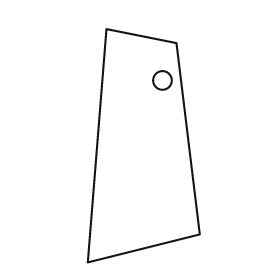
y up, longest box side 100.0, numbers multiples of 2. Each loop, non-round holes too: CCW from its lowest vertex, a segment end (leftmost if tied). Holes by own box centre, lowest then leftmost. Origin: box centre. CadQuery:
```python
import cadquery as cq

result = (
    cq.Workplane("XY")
    .moveTo(-24.0, -50.0)
    .lineTo(24.0, -38.0)
    .lineTo(14.0, 44.0)
    .lineTo(-16.0, 50.0)
    .close()
    .moveTo(8.0, 28.0)
    .circle(4.0)
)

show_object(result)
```